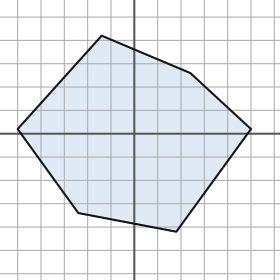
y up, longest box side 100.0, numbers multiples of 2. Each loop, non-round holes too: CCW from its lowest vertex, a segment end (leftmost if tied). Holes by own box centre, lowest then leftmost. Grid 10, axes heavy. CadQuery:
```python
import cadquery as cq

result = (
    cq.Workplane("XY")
    .moveTo(18.0, -42.0)
    .lineTo(50.0, 2.0)
    .lineTo(24.0, 26.0)
    .lineTo(-14.0, 42.0)
    .lineTo(-50.0, 2.0)
    .lineTo(-24.0, -34.0)
    .close()
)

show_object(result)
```